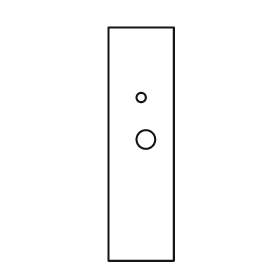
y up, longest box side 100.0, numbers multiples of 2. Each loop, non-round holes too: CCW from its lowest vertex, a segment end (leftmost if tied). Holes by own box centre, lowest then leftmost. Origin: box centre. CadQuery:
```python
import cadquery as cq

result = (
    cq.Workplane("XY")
    .moveTo(-14.0, -50.0)
    .lineTo(14.0, -50.0)
    .lineTo(14.0, 50.0)
    .lineTo(-14.0, 50.0)
    .close()
    .moveTo(2.0, 2.0)
    .circle(4.0)
    .moveTo(0.0, 20.0)
    .circle(2.0)
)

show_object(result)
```